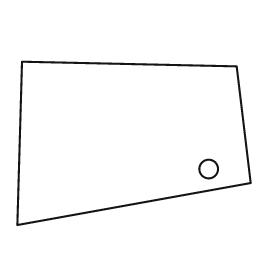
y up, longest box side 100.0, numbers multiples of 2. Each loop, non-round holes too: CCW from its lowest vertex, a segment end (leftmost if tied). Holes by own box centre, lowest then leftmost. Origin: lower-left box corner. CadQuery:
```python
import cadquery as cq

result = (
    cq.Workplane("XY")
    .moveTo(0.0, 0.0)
    .lineTo(100.0, 18.0)
    .lineTo(94.0, 68.0)
    .lineTo(2.0, 70.0)
    .close()
    .moveTo(82.0, 24.0)
    .circle(4.0)
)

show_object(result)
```